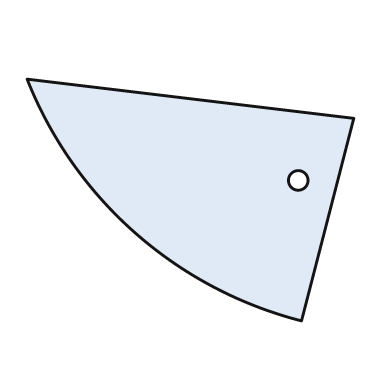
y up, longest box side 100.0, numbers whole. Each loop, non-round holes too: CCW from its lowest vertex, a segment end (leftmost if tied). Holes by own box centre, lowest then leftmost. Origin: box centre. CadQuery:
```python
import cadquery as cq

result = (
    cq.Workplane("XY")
    .moveTo(34.0, -37.0)
    .lineTo(50.0, 25.0)
    .lineTo(-50.0, 37.0)
    .threePointArc((-17.0, -10.0), (34.0, -37.0))
    .close()
    .moveTo(33.0, 6.0)
    .circle(3.0)
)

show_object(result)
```